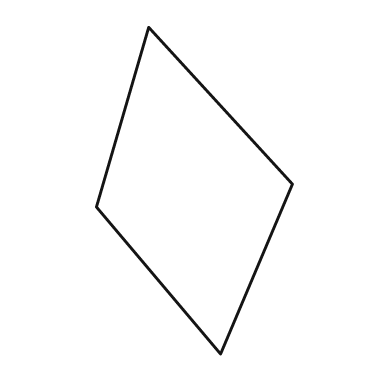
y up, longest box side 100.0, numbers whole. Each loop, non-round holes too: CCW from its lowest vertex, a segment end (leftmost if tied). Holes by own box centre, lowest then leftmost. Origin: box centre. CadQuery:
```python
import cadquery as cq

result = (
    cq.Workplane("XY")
    .moveTo(8.0, -50.0)
    .lineTo(30.0, 2.0)
    .lineTo(-14.0, 50.0)
    .lineTo(-30.0, -5.0)
    .close()
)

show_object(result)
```